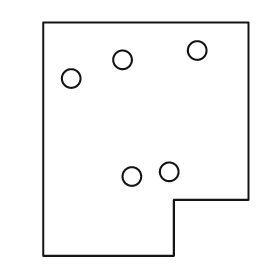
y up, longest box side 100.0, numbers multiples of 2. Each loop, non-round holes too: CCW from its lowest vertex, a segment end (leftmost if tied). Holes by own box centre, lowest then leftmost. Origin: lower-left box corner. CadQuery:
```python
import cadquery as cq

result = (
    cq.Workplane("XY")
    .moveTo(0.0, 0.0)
    .lineTo(56.0, 0.0)
    .lineTo(56.0, 24.0)
    .lineTo(88.0, 24.0)
    .lineTo(88.0, 100.0)
    .lineTo(0.0, 100.0)
    .close()
    .moveTo(38.0, 34.0)
    .circle(4.0)
    .moveTo(54.0, 36.0)
    .circle(4.0)
    .moveTo(12.0, 76.0)
    .circle(4.0)
    .moveTo(34.0, 84.0)
    .circle(4.0)
    .moveTo(66.0, 88.0)
    .circle(4.0)
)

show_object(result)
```